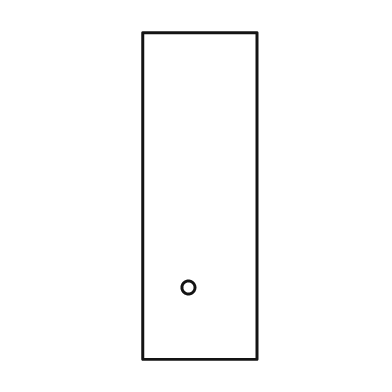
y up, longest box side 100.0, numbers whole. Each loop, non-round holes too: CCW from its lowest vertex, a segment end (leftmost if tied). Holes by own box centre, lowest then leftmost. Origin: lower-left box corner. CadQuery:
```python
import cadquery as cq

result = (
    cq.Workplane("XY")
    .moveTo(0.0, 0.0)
    .lineTo(35.0, 0.0)
    .lineTo(35.0, 100.0)
    .lineTo(0.0, 100.0)
    .close()
    .moveTo(14.0, 22.0)
    .circle(2.0)
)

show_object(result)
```